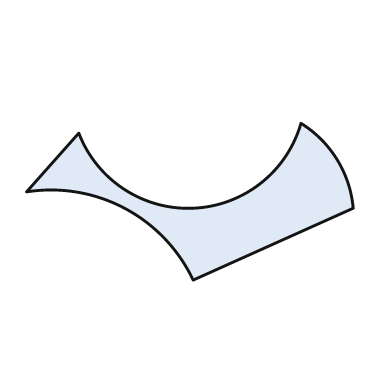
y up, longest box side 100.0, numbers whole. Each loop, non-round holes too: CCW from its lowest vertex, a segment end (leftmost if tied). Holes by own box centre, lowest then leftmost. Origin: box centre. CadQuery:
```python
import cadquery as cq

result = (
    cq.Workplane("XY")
    .moveTo(1.0, -24.0)
    .lineTo(50.0, -2.0)
    .threePointArc((45.0, 13.0), (34.0, 24.0))
    .threePointArc((1.0, -2.0), (-34.0, 21.0))
    .lineTo(-50.0, 3.0)
    .threePointArc((-20.0, -2.0), (1.0, -24.0))
    .close()
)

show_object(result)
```